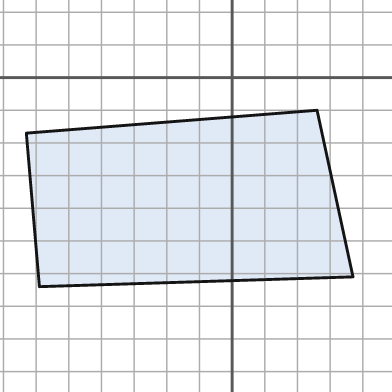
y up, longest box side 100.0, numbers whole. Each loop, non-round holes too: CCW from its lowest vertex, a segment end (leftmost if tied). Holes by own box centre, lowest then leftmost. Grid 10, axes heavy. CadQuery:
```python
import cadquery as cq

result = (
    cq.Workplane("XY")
    .moveTo(-59.0, -64.0)
    .lineTo(37.0, -61.0)
    .lineTo(26.0, -10.0)
    .lineTo(-63.0, -17.0)
    .close()
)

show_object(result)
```